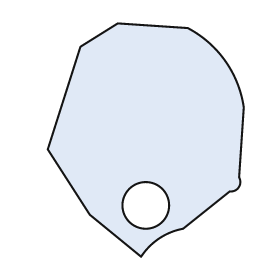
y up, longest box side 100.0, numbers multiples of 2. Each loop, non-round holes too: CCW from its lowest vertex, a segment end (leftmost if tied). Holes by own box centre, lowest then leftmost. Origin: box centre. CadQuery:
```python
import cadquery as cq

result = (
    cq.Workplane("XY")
    .moveTo(-2.0, -50.0)
    .threePointArc((6.0, -42.0), (16.0, -38.0))
    .lineTo(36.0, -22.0)
    .threePointArc((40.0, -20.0), (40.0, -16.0))
    .lineTo(42.0, 14.0)
    .threePointArc((34.0, 34.0), (18.0, 48.0))
    .lineTo(-12.0, 50.0)
    .lineTo(-28.0, 40.0)
    .lineTo(-42.0, -4.0)
    .lineTo(-24.0, -32.0)
    .close()
    .moveTo(0.0, -28.0)
    .circle(10.0)
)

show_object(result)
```